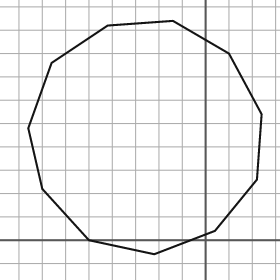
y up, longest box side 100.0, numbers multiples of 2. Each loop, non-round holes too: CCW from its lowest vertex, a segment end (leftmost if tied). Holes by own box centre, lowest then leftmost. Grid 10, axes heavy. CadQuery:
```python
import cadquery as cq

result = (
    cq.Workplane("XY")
    .moveTo(-22.0, -6.0)
    .lineTo(4.0, 4.0)
    .lineTo(22.0, 26.0)
    .lineTo(24.0, 54.0)
    .lineTo(10.0, 80.0)
    .lineTo(-14.0, 94.0)
    .lineTo(-42.0, 92.0)
    .lineTo(-66.0, 76.0)
    .lineTo(-76.0, 48.0)
    .lineTo(-70.0, 22.0)
    .lineTo(-50.0, 0.0)
    .close()
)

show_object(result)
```